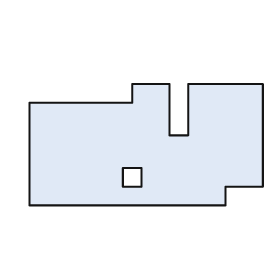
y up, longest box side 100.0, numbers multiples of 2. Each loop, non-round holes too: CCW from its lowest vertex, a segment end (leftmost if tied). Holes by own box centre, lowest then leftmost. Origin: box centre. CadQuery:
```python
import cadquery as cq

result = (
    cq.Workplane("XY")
    .moveTo(-50.0, -26.0)
    .lineTo(34.0, -26.0)
    .lineTo(34.0, -18.0)
    .lineTo(50.0, -18.0)
    .lineTo(50.0, 26.0)
    .lineTo(18.0, 26.0)
    .lineTo(18.0, 4.0)
    .lineTo(10.0, 4.0)
    .lineTo(10.0, 26.0)
    .lineTo(-6.0, 26.0)
    .lineTo(-6.0, 18.0)
    .lineTo(-50.0, 18.0)
    .close()
    .moveTo(-10.0, -18.0)
    .lineTo(-2.0, -18.0)
    .lineTo(-2.0, -10.0)
    .lineTo(-10.0, -10.0)
    .close()
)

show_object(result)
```